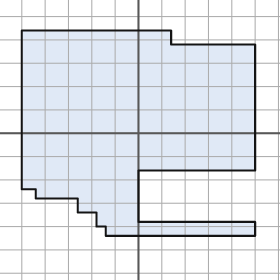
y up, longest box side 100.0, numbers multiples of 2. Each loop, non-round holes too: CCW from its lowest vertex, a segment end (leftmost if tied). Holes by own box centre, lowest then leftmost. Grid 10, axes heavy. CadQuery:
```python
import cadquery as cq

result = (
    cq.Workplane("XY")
    .moveTo(-14.0, -44.0)
    .lineTo(50.0, -44.0)
    .lineTo(50.0, -38.0)
    .lineTo(0.0, -38.0)
    .lineTo(0.0, -16.0)
    .lineTo(50.0, -16.0)
    .lineTo(50.0, 38.0)
    .lineTo(14.0, 38.0)
    .lineTo(14.0, 44.0)
    .lineTo(-50.0, 44.0)
    .lineTo(-50.0, -24.0)
    .lineTo(-44.0, -24.0)
    .lineTo(-44.0, -28.0)
    .lineTo(-26.0, -28.0)
    .lineTo(-26.0, -34.0)
    .lineTo(-18.0, -34.0)
    .lineTo(-18.0, -40.0)
    .lineTo(-14.0, -40.0)
    .close()
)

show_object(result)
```